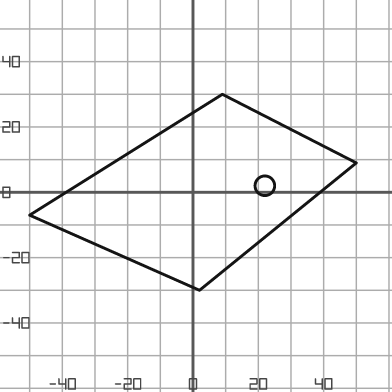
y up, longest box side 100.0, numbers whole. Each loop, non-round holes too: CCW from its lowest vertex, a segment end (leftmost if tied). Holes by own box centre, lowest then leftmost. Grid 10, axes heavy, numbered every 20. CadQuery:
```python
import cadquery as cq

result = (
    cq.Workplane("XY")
    .moveTo(2.0, -30.0)
    .lineTo(50.0, 9.0)
    .lineTo(9.0, 30.0)
    .lineTo(-50.0, -7.0)
    .close()
    .moveTo(22.0, 2.0)
    .circle(3.0)
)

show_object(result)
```